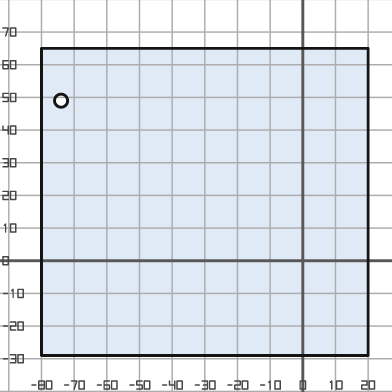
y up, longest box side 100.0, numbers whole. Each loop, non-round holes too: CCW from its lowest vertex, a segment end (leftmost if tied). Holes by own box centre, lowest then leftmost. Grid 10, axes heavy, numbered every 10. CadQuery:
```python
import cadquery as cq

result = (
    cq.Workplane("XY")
    .moveTo(-80.0, -29.0)
    .lineTo(20.0, -29.0)
    .lineTo(20.0, 65.0)
    .lineTo(-80.0, 65.0)
    .close()
    .moveTo(-74.0, 49.0)
    .circle(2.0)
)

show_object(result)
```